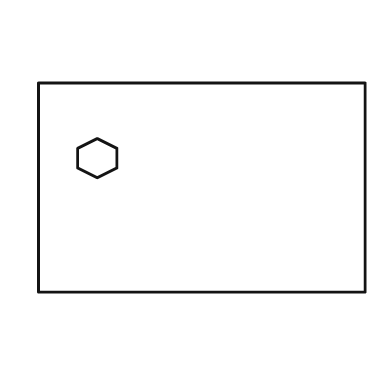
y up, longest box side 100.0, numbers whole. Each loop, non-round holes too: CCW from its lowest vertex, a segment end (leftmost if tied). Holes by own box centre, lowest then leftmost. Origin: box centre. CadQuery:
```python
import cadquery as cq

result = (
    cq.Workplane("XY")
    .moveTo(-50.0, -32.0)
    .lineTo(50.0, -32.0)
    .lineTo(50.0, 32.0)
    .lineTo(-50.0, 32.0)
    .close()
    .moveTo(-32.0, 3.0)
    .lineTo(-26.0, 6.0)
    .lineTo(-26.0, 12.0)
    .lineTo(-32.0, 15.0)
    .lineTo(-38.0, 12.0)
    .lineTo(-38.0, 6.0)
    .close()
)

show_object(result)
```